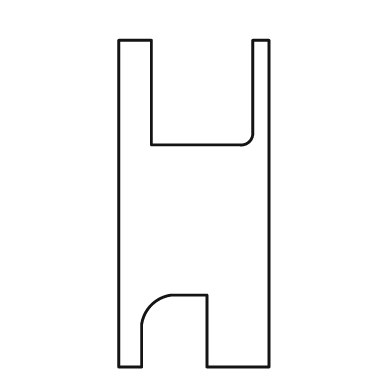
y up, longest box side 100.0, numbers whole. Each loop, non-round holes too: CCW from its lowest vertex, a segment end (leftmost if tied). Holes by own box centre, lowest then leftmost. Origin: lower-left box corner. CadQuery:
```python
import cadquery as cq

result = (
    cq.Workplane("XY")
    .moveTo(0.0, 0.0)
    .lineTo(7.0, 0.0)
    .lineTo(7.0, 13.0)
    .threePointArc((10.0, 19.0), (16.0, 22.0))
    .lineTo(27.0, 22.0)
    .lineTo(27.0, 0.0)
    .lineTo(46.0, 0.0)
    .lineTo(46.0, 100.0)
    .lineTo(41.0, 100.0)
    .lineTo(41.0, 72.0)
    .threePointArc((40.0, 69.0), (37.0, 68.0))
    .lineTo(10.0, 68.0)
    .lineTo(10.0, 100.0)
    .lineTo(0.0, 100.0)
    .close()
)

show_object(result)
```